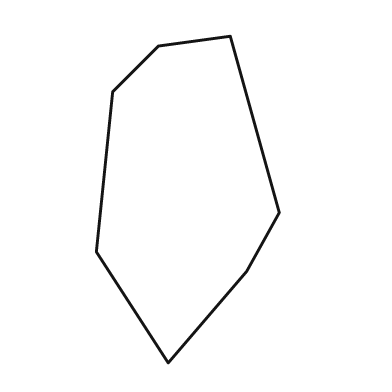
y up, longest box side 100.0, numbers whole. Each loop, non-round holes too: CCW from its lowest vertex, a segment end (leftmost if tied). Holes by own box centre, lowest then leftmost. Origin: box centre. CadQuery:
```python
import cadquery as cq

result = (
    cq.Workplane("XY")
    .moveTo(-6.0, -50.0)
    .lineTo(18.0, -22.0)
    .lineTo(28.0, -4.0)
    .lineTo(13.0, 50.0)
    .lineTo(-9.0, 47.0)
    .lineTo(-23.0, 33.0)
    .lineTo(-28.0, -16.0)
    .close()
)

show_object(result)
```